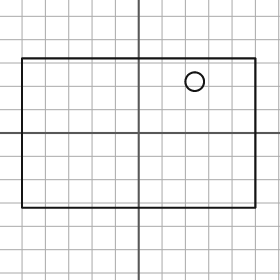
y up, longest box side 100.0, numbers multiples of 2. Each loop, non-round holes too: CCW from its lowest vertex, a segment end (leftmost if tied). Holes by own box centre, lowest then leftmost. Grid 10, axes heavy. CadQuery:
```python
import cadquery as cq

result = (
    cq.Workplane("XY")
    .moveTo(-50.0, -32.0)
    .lineTo(50.0, -32.0)
    .lineTo(50.0, 32.0)
    .lineTo(-50.0, 32.0)
    .close()
    .moveTo(24.0, 22.0)
    .circle(4.0)
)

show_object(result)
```